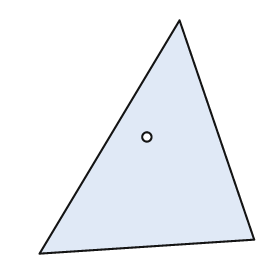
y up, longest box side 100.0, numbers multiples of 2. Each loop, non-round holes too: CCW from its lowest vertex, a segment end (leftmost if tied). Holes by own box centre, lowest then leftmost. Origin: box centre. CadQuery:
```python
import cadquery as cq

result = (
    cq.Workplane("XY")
    .moveTo(-46.0, -50.0)
    .lineTo(46.0, -44.0)
    .lineTo(14.0, 50.0)
    .close()
    .moveTo(0.0, 0.0)
    .circle(2.0)
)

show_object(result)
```